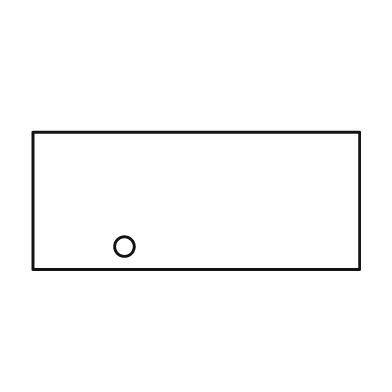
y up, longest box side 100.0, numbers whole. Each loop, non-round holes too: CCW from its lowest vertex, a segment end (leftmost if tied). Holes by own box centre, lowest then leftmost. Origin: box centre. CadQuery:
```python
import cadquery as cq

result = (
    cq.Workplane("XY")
    .moveTo(-50.0, -21.0)
    .lineTo(50.0, -21.0)
    .lineTo(50.0, 21.0)
    .lineTo(-50.0, 21.0)
    .close()
    .moveTo(-22.0, -14.0)
    .circle(3.0)
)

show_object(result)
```